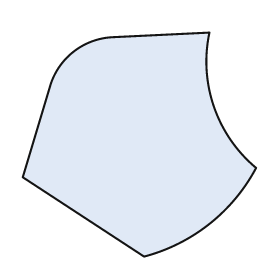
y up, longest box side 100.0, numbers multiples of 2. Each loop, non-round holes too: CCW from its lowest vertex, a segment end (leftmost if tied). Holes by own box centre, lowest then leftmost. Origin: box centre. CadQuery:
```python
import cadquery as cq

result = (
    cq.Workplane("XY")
    .moveTo(2.0, -48.0)
    .threePointArc((30.0, -34.0), (50.0, -10.0))
    .threePointArc((32.0, 16.0), (30.0, 48.0))
    .lineTo(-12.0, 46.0)
    .threePointArc((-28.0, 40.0), (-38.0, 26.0))
    .lineTo(-50.0, -14.0)
    .close()
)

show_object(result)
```